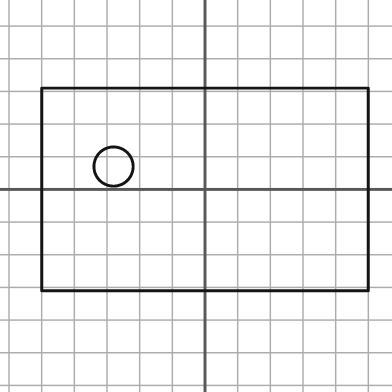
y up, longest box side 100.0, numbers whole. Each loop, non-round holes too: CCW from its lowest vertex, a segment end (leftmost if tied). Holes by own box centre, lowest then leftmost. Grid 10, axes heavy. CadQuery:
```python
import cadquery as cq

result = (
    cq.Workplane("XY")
    .moveTo(-50.0, -31.0)
    .lineTo(50.0, -31.0)
    .lineTo(50.0, 31.0)
    .lineTo(-50.0, 31.0)
    .close()
    .moveTo(-28.0, 7.0)
    .circle(6.0)
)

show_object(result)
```